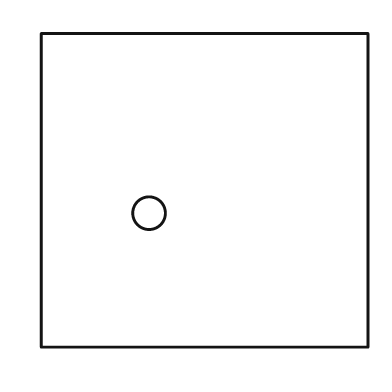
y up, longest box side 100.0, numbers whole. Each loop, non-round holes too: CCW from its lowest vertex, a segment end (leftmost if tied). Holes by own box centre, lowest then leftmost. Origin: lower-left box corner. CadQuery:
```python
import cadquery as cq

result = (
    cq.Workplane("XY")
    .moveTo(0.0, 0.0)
    .lineTo(100.0, 0.0)
    .lineTo(100.0, 96.0)
    .lineTo(0.0, 96.0)
    .close()
    .moveTo(33.0, 41.0)
    .circle(5.0)
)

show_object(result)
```